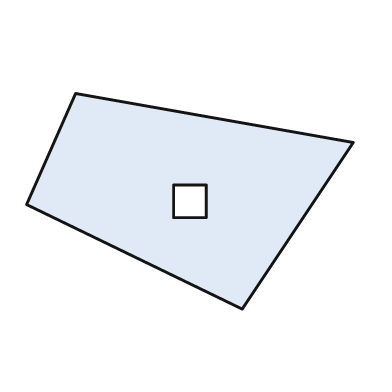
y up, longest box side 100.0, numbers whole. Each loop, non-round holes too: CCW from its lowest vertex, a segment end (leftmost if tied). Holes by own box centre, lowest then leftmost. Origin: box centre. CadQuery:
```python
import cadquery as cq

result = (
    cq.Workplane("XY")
    .moveTo(16.0, -33.0)
    .lineTo(50.0, 18.0)
    .lineTo(-35.0, 33.0)
    .lineTo(-50.0, -1.0)
    .close()
    .moveTo(-5.0, -5.0)
    .lineTo(5.0, -5.0)
    .lineTo(5.0, 5.0)
    .lineTo(-5.0, 5.0)
    .close()
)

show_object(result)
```